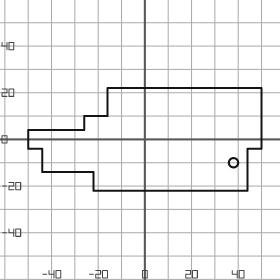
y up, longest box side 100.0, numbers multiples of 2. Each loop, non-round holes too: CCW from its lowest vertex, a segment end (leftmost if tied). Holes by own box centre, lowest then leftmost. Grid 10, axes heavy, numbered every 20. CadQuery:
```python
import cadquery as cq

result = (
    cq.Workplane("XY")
    .moveTo(-22.0, -22.0)
    .lineTo(44.0, -22.0)
    .lineTo(44.0, -4.0)
    .lineTo(50.0, -4.0)
    .lineTo(50.0, 22.0)
    .lineTo(-16.0, 22.0)
    .lineTo(-16.0, 10.0)
    .lineTo(-26.0, 10.0)
    .lineTo(-26.0, 4.0)
    .lineTo(-50.0, 4.0)
    .lineTo(-50.0, -4.0)
    .lineTo(-44.0, -4.0)
    .lineTo(-44.0, -14.0)
    .lineTo(-22.0, -14.0)
    .close()
    .moveTo(38.0, -10.0)
    .circle(2.0)
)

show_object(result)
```